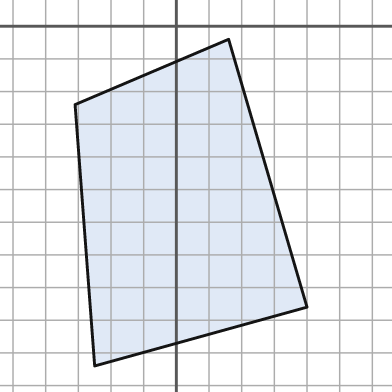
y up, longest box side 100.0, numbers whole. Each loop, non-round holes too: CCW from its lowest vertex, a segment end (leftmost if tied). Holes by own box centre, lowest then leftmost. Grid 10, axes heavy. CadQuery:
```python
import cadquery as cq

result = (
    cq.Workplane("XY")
    .moveTo(-25.0, -104.0)
    .lineTo(40.0, -86.0)
    .lineTo(16.0, -4.0)
    .lineTo(-31.0, -24.0)
    .close()
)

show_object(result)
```